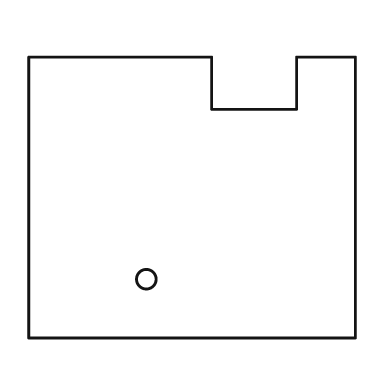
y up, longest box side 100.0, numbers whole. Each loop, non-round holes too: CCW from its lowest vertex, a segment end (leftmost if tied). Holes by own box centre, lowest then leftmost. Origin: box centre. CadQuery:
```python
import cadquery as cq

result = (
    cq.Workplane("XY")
    .moveTo(-50.0, -43.0)
    .lineTo(50.0, -43.0)
    .lineTo(50.0, 43.0)
    .lineTo(32.0, 43.0)
    .lineTo(32.0, 27.0)
    .lineTo(6.0, 27.0)
    .lineTo(6.0, 43.0)
    .lineTo(-50.0, 43.0)
    .close()
    .moveTo(-14.0, -25.0)
    .circle(3.0)
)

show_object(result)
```